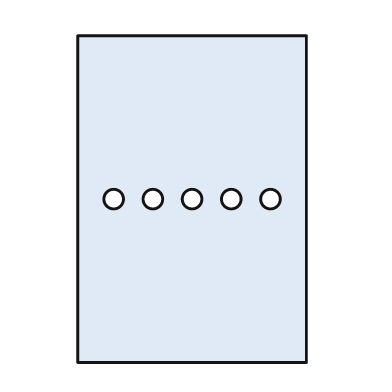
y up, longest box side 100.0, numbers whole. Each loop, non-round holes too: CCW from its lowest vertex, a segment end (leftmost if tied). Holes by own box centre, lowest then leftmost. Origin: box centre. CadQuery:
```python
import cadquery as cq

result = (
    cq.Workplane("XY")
    .moveTo(-35.0, -50.0)
    .lineTo(35.0, -50.0)
    .lineTo(35.0, 50.0)
    .lineTo(-35.0, 50.0)
    .close()
    .moveTo(-24.0, 0.0)
    .circle(3.0)
    .moveTo(-12.0, 0.0)
    .circle(3.0)
    .moveTo(0.0, 0.0)
    .circle(3.0)
    .moveTo(12.0, 0.0)
    .circle(3.0)
    .moveTo(24.0, 0.0)
    .circle(3.0)
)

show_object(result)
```